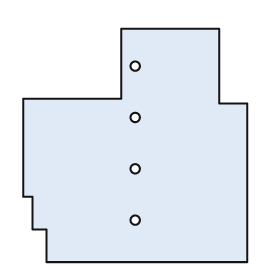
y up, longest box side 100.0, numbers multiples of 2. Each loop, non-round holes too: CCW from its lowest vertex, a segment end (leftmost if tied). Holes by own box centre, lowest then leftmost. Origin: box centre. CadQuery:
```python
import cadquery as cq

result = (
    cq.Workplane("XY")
    .moveTo(-38.0, -50.0)
    .lineTo(48.0, -50.0)
    .lineTo(48.0, 18.0)
    .lineTo(36.0, 18.0)
    .lineTo(36.0, 50.0)
    .lineTo(-6.0, 50.0)
    .lineTo(-6.0, 20.0)
    .lineTo(-48.0, 20.0)
    .lineTo(-48.0, -22.0)
    .lineTo(-44.0, -22.0)
    .lineTo(-44.0, -36.0)
    .lineTo(-38.0, -36.0)
    .close()
    .moveTo(0.0, -32.0)
    .circle(2.0)
    .moveTo(0.0, -10.0)
    .circle(2.0)
    .moveTo(0.0, 12.0)
    .circle(2.0)
    .moveTo(0.0, 34.0)
    .circle(2.0)
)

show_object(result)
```